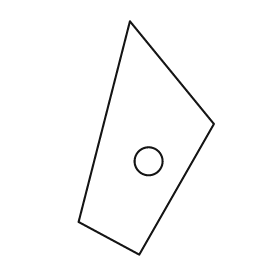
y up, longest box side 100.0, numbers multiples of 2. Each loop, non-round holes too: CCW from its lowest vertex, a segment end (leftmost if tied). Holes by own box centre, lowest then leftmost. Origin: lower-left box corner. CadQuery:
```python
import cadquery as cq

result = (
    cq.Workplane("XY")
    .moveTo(26.0, 0.0)
    .lineTo(58.0, 56.0)
    .lineTo(22.0, 100.0)
    .lineTo(0.0, 14.0)
    .close()
    .moveTo(30.0, 40.0)
    .circle(6.0)
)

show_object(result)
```